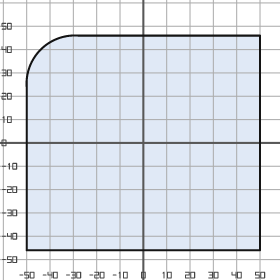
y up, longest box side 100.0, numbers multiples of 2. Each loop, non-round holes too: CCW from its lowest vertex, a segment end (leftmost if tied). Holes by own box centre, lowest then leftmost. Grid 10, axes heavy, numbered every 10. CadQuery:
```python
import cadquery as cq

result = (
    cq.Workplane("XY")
    .moveTo(-50.0, -46.0)
    .lineTo(50.0, -46.0)
    .lineTo(50.0, 46.0)
    .lineTo(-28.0, 46.0)
    .threePointArc((-44.0, 40.0), (-50.0, 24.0))
    .close()
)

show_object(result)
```